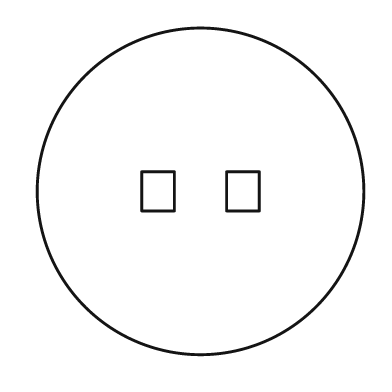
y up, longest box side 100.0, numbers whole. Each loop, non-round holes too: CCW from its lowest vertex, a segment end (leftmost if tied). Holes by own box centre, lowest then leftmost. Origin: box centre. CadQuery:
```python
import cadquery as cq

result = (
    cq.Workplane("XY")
    .moveTo(0.0, 0.0)
    .circle(50.0)
    .moveTo(-18.0, -6.0)
    .lineTo(-8.0, -6.0)
    .lineTo(-8.0, 6.0)
    .lineTo(-18.0, 6.0)
    .close()
    .moveTo(8.0, -6.0)
    .lineTo(18.0, -6.0)
    .lineTo(18.0, 6.0)
    .lineTo(8.0, 6.0)
    .close()
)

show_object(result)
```